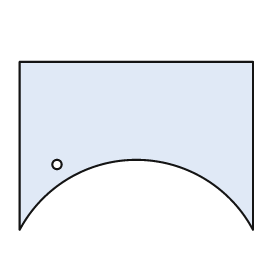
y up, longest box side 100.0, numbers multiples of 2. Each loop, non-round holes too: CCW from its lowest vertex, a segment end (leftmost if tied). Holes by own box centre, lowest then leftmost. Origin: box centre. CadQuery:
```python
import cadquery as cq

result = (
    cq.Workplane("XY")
    .moveTo(-50.0, -36.0)
    .threePointArc((0.0, -6.0), (50.0, -36.0))
    .lineTo(50.0, 36.0)
    .lineTo(-50.0, 36.0)
    .close()
    .moveTo(-34.0, -8.0)
    .circle(2.0)
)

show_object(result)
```